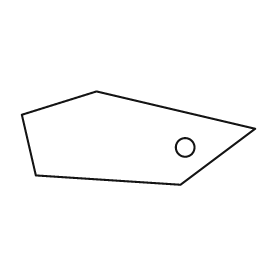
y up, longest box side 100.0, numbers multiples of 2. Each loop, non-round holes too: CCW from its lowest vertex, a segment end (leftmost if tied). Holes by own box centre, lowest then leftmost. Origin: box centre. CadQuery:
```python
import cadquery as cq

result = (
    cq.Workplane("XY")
    .moveTo(18.0, -20.0)
    .lineTo(50.0, 4.0)
    .lineTo(-18.0, 20.0)
    .lineTo(-50.0, 10.0)
    .lineTo(-44.0, -16.0)
    .close()
    .moveTo(20.0, -4.0)
    .circle(4.0)
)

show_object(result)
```